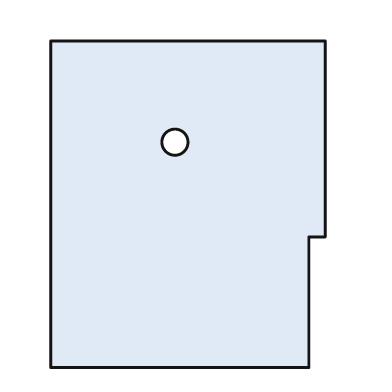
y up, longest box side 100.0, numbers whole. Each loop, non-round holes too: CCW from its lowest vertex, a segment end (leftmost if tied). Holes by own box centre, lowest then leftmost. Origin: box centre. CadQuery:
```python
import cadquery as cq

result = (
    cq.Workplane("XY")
    .moveTo(-42.0, -50.0)
    .lineTo(37.0, -50.0)
    .lineTo(37.0, -10.0)
    .lineTo(42.0, -10.0)
    .lineTo(42.0, 50.0)
    .lineTo(-42.0, 50.0)
    .close()
    .moveTo(-4.0, 19.0)
    .circle(4.0)
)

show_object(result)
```